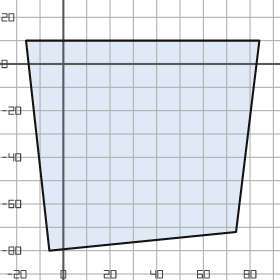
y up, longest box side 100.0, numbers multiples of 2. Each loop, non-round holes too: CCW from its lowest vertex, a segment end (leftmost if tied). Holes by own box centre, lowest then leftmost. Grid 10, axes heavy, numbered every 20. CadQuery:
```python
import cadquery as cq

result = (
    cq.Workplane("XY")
    .moveTo(-6.0, -80.0)
    .lineTo(74.0, -72.0)
    .lineTo(84.0, 10.0)
    .lineTo(-16.0, 10.0)
    .close()
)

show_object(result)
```